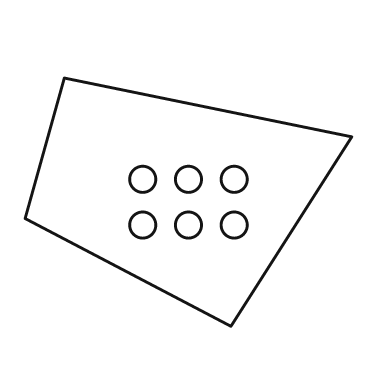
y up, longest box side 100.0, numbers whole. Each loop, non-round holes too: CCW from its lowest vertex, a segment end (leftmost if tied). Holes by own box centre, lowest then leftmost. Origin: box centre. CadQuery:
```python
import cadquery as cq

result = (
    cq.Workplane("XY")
    .moveTo(13.0, -38.0)
    .lineTo(50.0, 20.0)
    .lineTo(-38.0, 38.0)
    .lineTo(-50.0, -5.0)
    .close()
    .moveTo(-14.0, -7.0)
    .circle(4.0)
    .moveTo(0.0, -7.0)
    .circle(4.0)
    .moveTo(14.0, -7.0)
    .circle(4.0)
    .moveTo(-14.0, 7.0)
    .circle(4.0)
    .moveTo(0.0, 7.0)
    .circle(4.0)
    .moveTo(14.0, 7.0)
    .circle(4.0)
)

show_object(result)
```